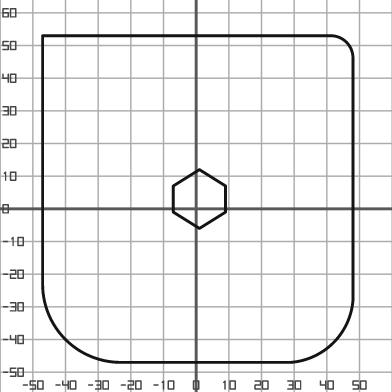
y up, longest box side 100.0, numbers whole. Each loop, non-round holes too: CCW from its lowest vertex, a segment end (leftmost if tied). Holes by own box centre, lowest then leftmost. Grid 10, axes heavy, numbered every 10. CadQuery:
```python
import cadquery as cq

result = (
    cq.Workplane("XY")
    .moveTo(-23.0, -47.0)
    .lineTo(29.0, -47.0)
    .threePointArc((42.0, -41.0), (48.0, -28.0))
    .lineTo(48.0, 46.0)
    .threePointArc((46.0, 51.0), (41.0, 53.0))
    .lineTo(-47.0, 53.0)
    .lineTo(-47.0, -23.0)
    .threePointArc((-40.0, -40.0), (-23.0, -47.0))
    .close()
    .moveTo(1.0, -6.0)
    .lineTo(9.0, -1.0)
    .lineTo(9.0, 7.0)
    .lineTo(1.0, 12.0)
    .lineTo(-7.0, 7.0)
    .lineTo(-7.0, -1.0)
    .close()
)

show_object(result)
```